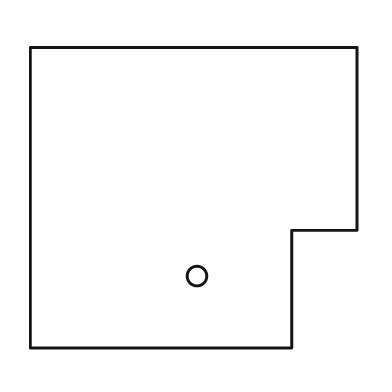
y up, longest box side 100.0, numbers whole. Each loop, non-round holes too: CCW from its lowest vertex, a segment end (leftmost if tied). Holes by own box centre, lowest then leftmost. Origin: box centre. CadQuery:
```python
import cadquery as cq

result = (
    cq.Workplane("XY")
    .moveTo(-50.0, -46.0)
    .lineTo(30.0, -46.0)
    .lineTo(30.0, -10.0)
    .lineTo(50.0, -10.0)
    .lineTo(50.0, 46.0)
    .lineTo(-50.0, 46.0)
    .close()
    .moveTo(1.0, -24.0)
    .circle(3.0)
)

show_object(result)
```